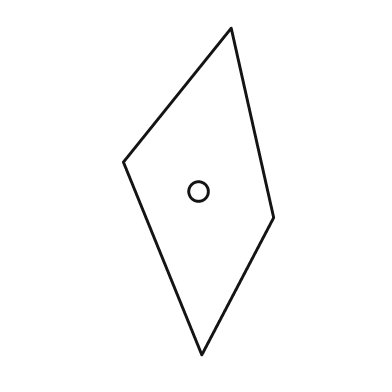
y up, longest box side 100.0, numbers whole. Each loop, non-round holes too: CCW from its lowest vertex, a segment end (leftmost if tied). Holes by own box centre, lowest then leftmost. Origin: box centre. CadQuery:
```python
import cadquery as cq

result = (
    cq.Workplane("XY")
    .moveTo(1.0, -50.0)
    .lineTo(23.0, -8.0)
    .lineTo(10.0, 50.0)
    .lineTo(-23.0, 9.0)
    .close()
    .moveTo(0.0, 0.0)
    .circle(3.0)
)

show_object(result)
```